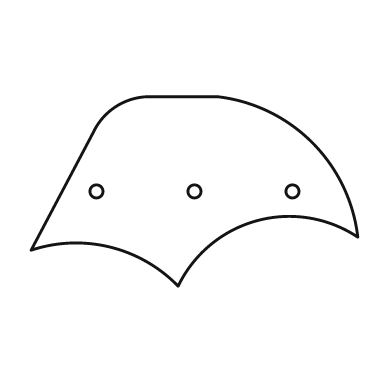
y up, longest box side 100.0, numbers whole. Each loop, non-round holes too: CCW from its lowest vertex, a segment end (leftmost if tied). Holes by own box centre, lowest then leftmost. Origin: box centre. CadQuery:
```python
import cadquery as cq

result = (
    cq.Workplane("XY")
    .moveTo(-5.0, -29.0)
    .threePointArc((19.0, -9.0), (50.0, -14.0))
    .threePointArc((36.0, 15.0), (7.0, 29.0))
    .lineTo(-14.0, 29.0)
    .threePointArc((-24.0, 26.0), (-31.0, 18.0))
    .lineTo(-50.0, -18.0)
    .threePointArc((-26.0, -17.0), (-5.0, -29.0))
    .close()
    .moveTo(-30.0, 0.0)
    .circle(2.0)
    .moveTo(0.0, 0.0)
    .circle(2.0)
    .moveTo(30.0, 0.0)
    .circle(2.0)
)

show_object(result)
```